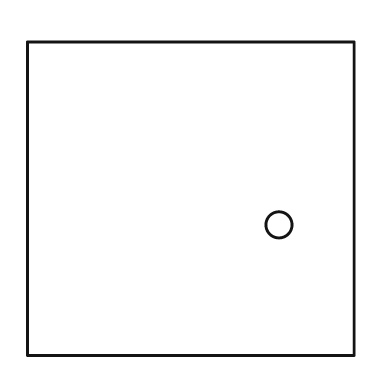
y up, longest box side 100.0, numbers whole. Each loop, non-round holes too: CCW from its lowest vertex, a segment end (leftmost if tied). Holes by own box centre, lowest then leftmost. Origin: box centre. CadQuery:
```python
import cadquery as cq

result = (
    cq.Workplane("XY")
    .moveTo(-50.0, -48.0)
    .lineTo(50.0, -48.0)
    .lineTo(50.0, 48.0)
    .lineTo(-50.0, 48.0)
    .close()
    .moveTo(27.0, -8.0)
    .circle(4.0)
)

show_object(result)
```